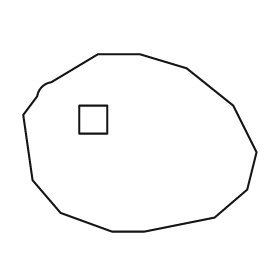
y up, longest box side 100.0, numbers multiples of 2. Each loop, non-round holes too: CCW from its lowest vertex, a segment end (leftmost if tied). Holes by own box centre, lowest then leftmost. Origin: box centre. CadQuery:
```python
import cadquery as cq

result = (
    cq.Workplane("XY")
    .moveTo(-12.0, -38.0)
    .lineTo(2.0, -38.0)
    .lineTo(32.0, -32.0)
    .lineTo(46.0, -20.0)
    .lineTo(50.0, -4.0)
    .lineTo(40.0, 16.0)
    .lineTo(20.0, 32.0)
    .lineTo(0.0, 38.0)
    .lineTo(-18.0, 38.0)
    .lineTo(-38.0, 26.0)
    .threePointArc((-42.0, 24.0), (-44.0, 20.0))
    .lineTo(-50.0, 12.0)
    .lineTo(-46.0, -16.0)
    .lineTo(-34.0, -30.0)
    .close()
    .moveTo(-26.0, 4.0)
    .lineTo(-14.0, 4.0)
    .lineTo(-14.0, 16.0)
    .lineTo(-26.0, 16.0)
    .close()
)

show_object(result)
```